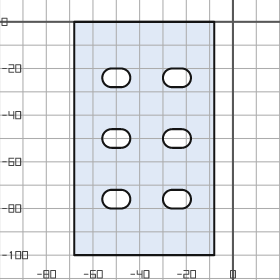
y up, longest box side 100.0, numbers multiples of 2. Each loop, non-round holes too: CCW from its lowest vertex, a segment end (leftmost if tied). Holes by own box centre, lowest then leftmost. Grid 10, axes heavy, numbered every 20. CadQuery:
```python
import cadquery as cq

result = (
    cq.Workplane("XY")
    .moveTo(-68.0, -100.0)
    .lineTo(-8.0, -100.0)
    .lineTo(-8.0, 0.0)
    .lineTo(-68.0, 0.0)
    .close()
    .moveTo(-52.0, -80.0)
    .lineTo(-48.0, -80.0)
    .threePointArc((-44.0, -76.0), (-48.0, -72.0))
    .lineTo(-52.0, -72.0)
    .threePointArc((-56.0, -76.0), (-52.0, -80.0))
    .close()
    .moveTo(-26.0, -80.0)
    .lineTo(-22.0, -80.0)
    .threePointArc((-18.0, -76.0), (-22.0, -72.0))
    .lineTo(-26.0, -72.0)
    .threePointArc((-30.0, -76.0), (-26.0, -80.0))
    .close()
    .moveTo(-52.0, -54.0)
    .lineTo(-48.0, -54.0)
    .threePointArc((-44.0, -50.0), (-48.0, -46.0))
    .lineTo(-52.0, -46.0)
    .threePointArc((-56.0, -50.0), (-52.0, -54.0))
    .close()
    .moveTo(-26.0, -54.0)
    .lineTo(-22.0, -54.0)
    .threePointArc((-18.0, -50.0), (-22.0, -46.0))
    .lineTo(-26.0, -46.0)
    .threePointArc((-30.0, -50.0), (-26.0, -54.0))
    .close()
    .moveTo(-52.0, -28.0)
    .lineTo(-48.0, -28.0)
    .threePointArc((-44.0, -24.0), (-48.0, -20.0))
    .lineTo(-52.0, -20.0)
    .threePointArc((-56.0, -24.0), (-52.0, -28.0))
    .close()
    .moveTo(-26.0, -28.0)
    .lineTo(-22.0, -28.0)
    .threePointArc((-18.0, -24.0), (-22.0, -20.0))
    .lineTo(-26.0, -20.0)
    .threePointArc((-30.0, -24.0), (-26.0, -28.0))
    .close()
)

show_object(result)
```